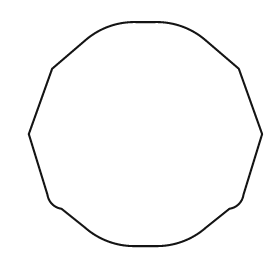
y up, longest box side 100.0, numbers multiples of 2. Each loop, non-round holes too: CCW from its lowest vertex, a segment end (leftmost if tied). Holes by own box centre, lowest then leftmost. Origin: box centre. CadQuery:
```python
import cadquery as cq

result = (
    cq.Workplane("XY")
    .moveTo(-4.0, -48.0)
    .lineTo(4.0, -48.0)
    .threePointArc((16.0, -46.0), (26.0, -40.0))
    .lineTo(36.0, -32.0)
    .threePointArc((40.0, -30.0), (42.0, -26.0))
    .lineTo(50.0, 0.0)
    .lineTo(40.0, 28.0)
    .lineTo(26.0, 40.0)
    .threePointArc((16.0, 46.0), (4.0, 48.0))
    .lineTo(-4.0, 48.0)
    .threePointArc((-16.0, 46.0), (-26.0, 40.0))
    .lineTo(-40.0, 28.0)
    .lineTo(-50.0, 0.0)
    .lineTo(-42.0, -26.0)
    .threePointArc((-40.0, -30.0), (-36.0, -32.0))
    .lineTo(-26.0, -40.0)
    .threePointArc((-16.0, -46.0), (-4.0, -48.0))
    .close()
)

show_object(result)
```